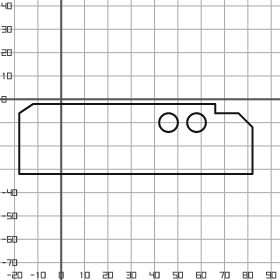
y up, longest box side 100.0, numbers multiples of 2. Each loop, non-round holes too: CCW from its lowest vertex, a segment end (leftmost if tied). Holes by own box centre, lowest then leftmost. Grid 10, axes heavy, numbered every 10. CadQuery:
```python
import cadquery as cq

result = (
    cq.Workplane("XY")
    .moveTo(-18.0, -32.0)
    .lineTo(82.0, -32.0)
    .lineTo(82.0, -12.0)
    .lineTo(76.0, -6.0)
    .lineTo(66.0, -6.0)
    .lineTo(66.0, -2.0)
    .lineTo(-12.0, -2.0)
    .lineTo(-18.0, -6.0)
    .close()
    .moveTo(46.0, -10.0)
    .circle(4.0)
    .moveTo(58.0, -10.0)
    .circle(4.0)
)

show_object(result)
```